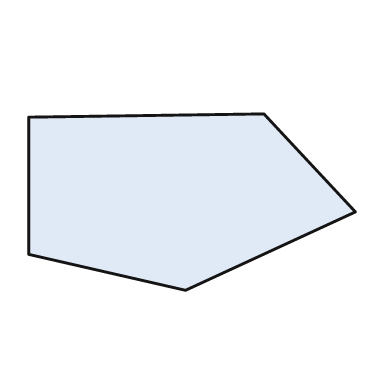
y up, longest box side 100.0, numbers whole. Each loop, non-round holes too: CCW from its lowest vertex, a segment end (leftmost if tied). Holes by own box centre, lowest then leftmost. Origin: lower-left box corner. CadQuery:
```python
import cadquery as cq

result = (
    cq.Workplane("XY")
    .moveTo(48.0, 0.0)
    .lineTo(100.0, 24.0)
    .lineTo(72.0, 54.0)
    .lineTo(0.0, 53.0)
    .lineTo(0.0, 11.0)
    .close()
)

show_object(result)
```